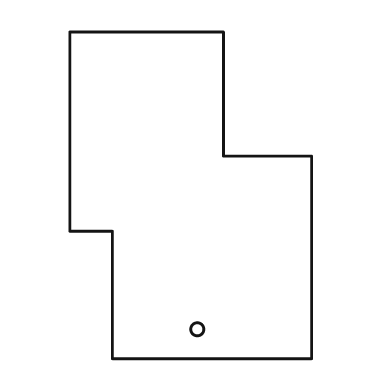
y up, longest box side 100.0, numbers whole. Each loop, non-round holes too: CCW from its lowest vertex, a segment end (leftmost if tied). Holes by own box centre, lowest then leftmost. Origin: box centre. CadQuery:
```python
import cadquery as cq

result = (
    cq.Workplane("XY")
    .moveTo(-24.0, -50.0)
    .lineTo(37.0, -50.0)
    .lineTo(37.0, 12.0)
    .lineTo(10.0, 12.0)
    .lineTo(10.0, 50.0)
    .lineTo(-37.0, 50.0)
    .lineTo(-37.0, -11.0)
    .lineTo(-24.0, -11.0)
    .close()
    .moveTo(2.0, -41.0)
    .circle(2.0)
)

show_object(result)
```